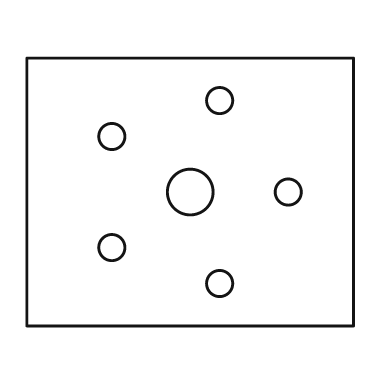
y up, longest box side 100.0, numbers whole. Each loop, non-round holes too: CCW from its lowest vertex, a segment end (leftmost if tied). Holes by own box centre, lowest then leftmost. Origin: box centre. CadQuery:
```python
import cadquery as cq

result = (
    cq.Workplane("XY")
    .moveTo(-50.0, -41.0)
    .lineTo(50.0, -41.0)
    .lineTo(50.0, 41.0)
    .lineTo(-50.0, 41.0)
    .close()
    .moveTo(9.0, -28.0)
    .circle(4.0)
    .moveTo(-24.0, -17.0)
    .circle(4.0)
    .moveTo(0.0, 0.0)
    .circle(7.0)
    .moveTo(30.0, 0.0)
    .circle(4.0)
    .moveTo(-24.0, 17.0)
    .circle(4.0)
    .moveTo(9.0, 28.0)
    .circle(4.0)
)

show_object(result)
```